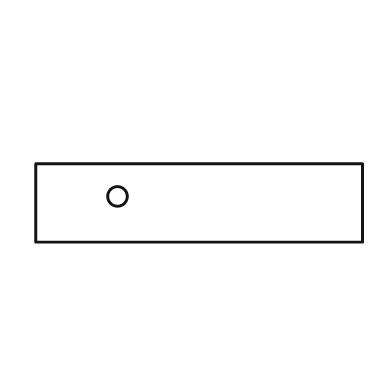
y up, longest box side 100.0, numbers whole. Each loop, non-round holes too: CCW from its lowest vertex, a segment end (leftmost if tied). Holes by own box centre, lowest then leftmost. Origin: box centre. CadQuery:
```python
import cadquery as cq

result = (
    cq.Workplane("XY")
    .moveTo(-50.0, -12.0)
    .lineTo(50.0, -12.0)
    .lineTo(50.0, 12.0)
    .lineTo(-50.0, 12.0)
    .close()
    .moveTo(-25.0, 2.0)
    .circle(3.0)
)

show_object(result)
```